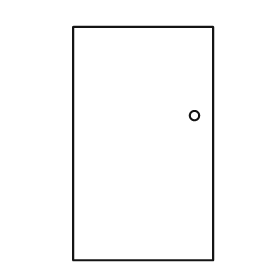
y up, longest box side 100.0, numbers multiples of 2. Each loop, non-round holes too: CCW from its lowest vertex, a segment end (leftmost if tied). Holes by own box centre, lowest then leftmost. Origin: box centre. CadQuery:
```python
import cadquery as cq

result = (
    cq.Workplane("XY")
    .moveTo(-30.0, -50.0)
    .lineTo(30.0, -50.0)
    .lineTo(30.0, 50.0)
    .lineTo(-30.0, 50.0)
    .close()
    .moveTo(22.0, 12.0)
    .circle(2.0)
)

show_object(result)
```